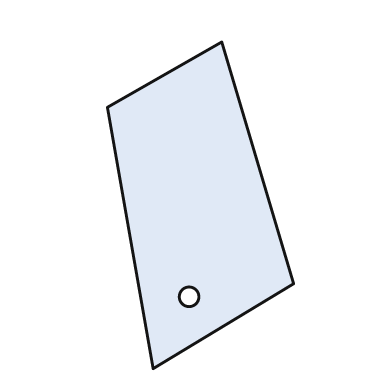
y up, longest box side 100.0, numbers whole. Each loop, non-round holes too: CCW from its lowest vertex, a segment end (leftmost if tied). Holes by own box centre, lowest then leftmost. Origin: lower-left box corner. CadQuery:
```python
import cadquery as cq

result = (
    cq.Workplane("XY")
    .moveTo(14.0, 0.0)
    .lineTo(57.0, 26.0)
    .lineTo(35.0, 100.0)
    .lineTo(0.0, 80.0)
    .close()
    .moveTo(25.0, 22.0)
    .circle(3.0)
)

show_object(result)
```